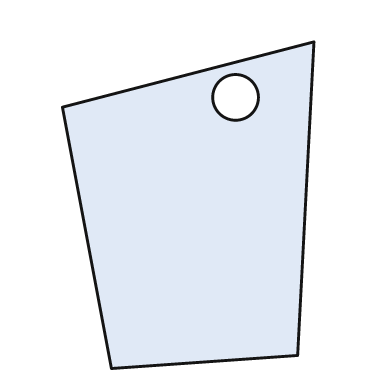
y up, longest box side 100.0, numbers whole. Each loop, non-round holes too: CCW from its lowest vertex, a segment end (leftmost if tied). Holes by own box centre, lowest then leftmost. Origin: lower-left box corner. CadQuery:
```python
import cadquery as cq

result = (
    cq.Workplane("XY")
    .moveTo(15.0, 0.0)
    .lineTo(72.0, 4.0)
    .lineTo(77.0, 100.0)
    .lineTo(0.0, 80.0)
    .close()
    .moveTo(53.0, 83.0)
    .circle(7.0)
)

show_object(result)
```